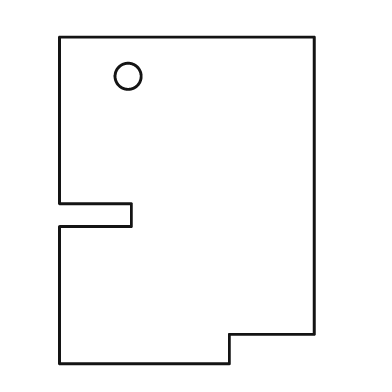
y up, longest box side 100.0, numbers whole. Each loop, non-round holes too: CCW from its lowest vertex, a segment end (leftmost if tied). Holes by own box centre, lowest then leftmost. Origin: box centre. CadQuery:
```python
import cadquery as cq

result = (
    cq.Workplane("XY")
    .moveTo(-39.0, -50.0)
    .lineTo(13.0, -50.0)
    .lineTo(13.0, -41.0)
    .lineTo(39.0, -41.0)
    .lineTo(39.0, 50.0)
    .lineTo(-39.0, 50.0)
    .lineTo(-39.0, -1.0)
    .lineTo(-17.0, -1.0)
    .lineTo(-17.0, -8.0)
    .lineTo(-39.0, -8.0)
    .close()
    .moveTo(-18.0, 38.0)
    .circle(4.0)
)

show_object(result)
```